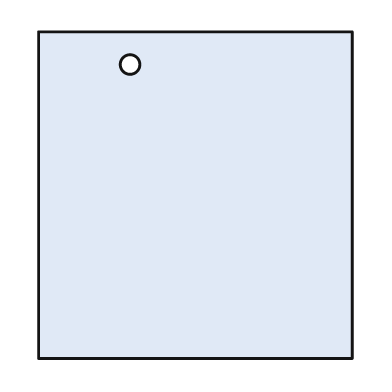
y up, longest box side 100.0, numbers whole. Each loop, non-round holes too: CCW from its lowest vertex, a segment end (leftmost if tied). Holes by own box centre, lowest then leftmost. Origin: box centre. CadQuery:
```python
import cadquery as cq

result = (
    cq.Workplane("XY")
    .moveTo(-48.0, -50.0)
    .lineTo(48.0, -50.0)
    .lineTo(48.0, 50.0)
    .lineTo(-48.0, 50.0)
    .close()
    .moveTo(-20.0, 40.0)
    .circle(3.0)
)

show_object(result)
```